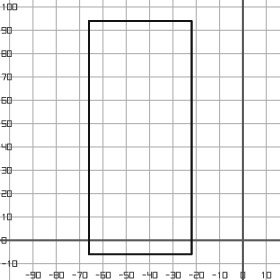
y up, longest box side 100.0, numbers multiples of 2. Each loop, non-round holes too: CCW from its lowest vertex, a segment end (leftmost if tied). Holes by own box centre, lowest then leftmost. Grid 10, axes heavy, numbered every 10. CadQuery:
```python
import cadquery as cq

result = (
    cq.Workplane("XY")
    .moveTo(-66.0, -6.0)
    .lineTo(-22.0, -6.0)
    .lineTo(-22.0, 94.0)
    .lineTo(-66.0, 94.0)
    .close()
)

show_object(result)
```